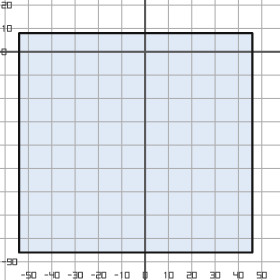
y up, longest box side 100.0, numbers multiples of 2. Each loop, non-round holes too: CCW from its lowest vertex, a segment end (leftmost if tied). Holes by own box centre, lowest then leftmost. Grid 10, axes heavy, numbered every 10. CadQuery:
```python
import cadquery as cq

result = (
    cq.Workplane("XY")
    .moveTo(-54.0, -86.0)
    .lineTo(46.0, -86.0)
    .lineTo(46.0, 8.0)
    .lineTo(-54.0, 8.0)
    .close()
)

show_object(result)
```